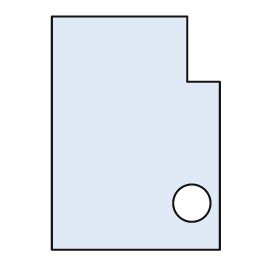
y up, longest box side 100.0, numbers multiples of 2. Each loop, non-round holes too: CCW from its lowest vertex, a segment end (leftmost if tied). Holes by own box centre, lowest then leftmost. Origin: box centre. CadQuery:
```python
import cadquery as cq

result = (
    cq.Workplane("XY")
    .moveTo(-36.0, -50.0)
    .lineTo(36.0, -50.0)
    .lineTo(36.0, 22.0)
    .lineTo(22.0, 22.0)
    .lineTo(22.0, 50.0)
    .lineTo(-36.0, 50.0)
    .close()
    .moveTo(24.0, -30.0)
    .circle(8.0)
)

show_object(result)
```